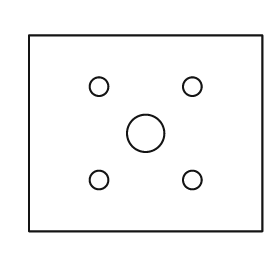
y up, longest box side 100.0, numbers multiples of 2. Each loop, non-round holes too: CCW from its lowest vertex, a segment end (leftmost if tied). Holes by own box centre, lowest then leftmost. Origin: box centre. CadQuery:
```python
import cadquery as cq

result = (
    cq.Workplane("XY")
    .moveTo(-50.0, -42.0)
    .lineTo(50.0, -42.0)
    .lineTo(50.0, 42.0)
    .lineTo(-50.0, 42.0)
    .close()
    .moveTo(-20.0, -20.0)
    .circle(4.0)
    .moveTo(20.0, -20.0)
    .circle(4.0)
    .moveTo(0.0, 0.0)
    .circle(8.0)
    .moveTo(-20.0, 20.0)
    .circle(4.0)
    .moveTo(20.0, 20.0)
    .circle(4.0)
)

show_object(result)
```